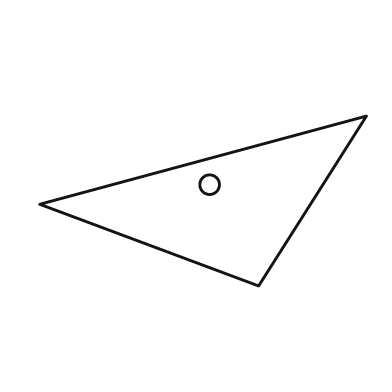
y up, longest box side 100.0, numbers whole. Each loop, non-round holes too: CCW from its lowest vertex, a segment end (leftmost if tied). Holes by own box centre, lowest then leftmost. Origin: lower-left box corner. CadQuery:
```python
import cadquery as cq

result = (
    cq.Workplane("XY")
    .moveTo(67.0, 0.0)
    .lineTo(100.0, 52.0)
    .lineTo(0.0, 25.0)
    .close()
    .moveTo(52.0, 31.0)
    .circle(3.0)
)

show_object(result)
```